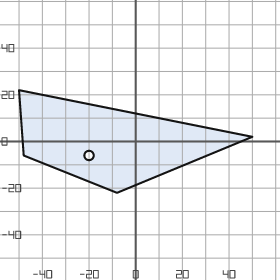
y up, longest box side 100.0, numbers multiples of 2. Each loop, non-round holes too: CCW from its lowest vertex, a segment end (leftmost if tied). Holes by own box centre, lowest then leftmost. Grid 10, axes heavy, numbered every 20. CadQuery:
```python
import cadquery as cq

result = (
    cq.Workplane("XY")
    .moveTo(-8.0, -22.0)
    .lineTo(50.0, 2.0)
    .lineTo(-50.0, 22.0)
    .lineTo(-48.0, -6.0)
    .close()
    .moveTo(-20.0, -6.0)
    .circle(2.0)
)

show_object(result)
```